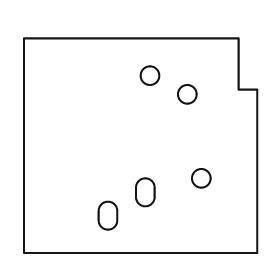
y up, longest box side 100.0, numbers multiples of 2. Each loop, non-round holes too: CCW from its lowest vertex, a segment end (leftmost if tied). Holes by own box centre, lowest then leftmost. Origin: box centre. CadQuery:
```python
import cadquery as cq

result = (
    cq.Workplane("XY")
    .moveTo(-50.0, -46.0)
    .lineTo(50.0, -46.0)
    .lineTo(50.0, 24.0)
    .lineTo(42.0, 24.0)
    .lineTo(42.0, 46.0)
    .lineTo(-50.0, 46.0)
    .close()
    .moveTo(-18.0, -32.0)
    .threePointArc((-14.0, -36.0), (-10.0, -32.0))
    .lineTo(-10.0, -28.0)
    .threePointArc((-14.0, -24.0), (-18.0, -28.0))
    .close()
    .moveTo(-2.0, -22.0)
    .threePointArc((2.0, -26.0), (6.0, -22.0))
    .lineTo(6.0, -18.0)
    .threePointArc((2.0, -14.0), (-2.0, -18.0))
    .close()
    .moveTo(26.0, -14.0)
    .circle(4.0)
    .moveTo(20.0, 22.0)
    .circle(4.0)
    .moveTo(4.0, 30.0)
    .circle(4.0)
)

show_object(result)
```